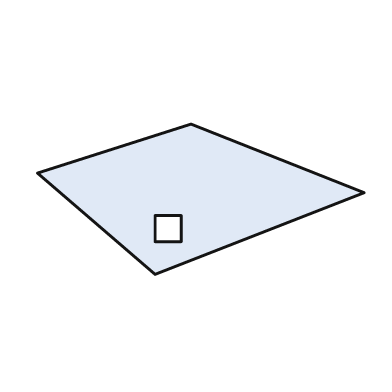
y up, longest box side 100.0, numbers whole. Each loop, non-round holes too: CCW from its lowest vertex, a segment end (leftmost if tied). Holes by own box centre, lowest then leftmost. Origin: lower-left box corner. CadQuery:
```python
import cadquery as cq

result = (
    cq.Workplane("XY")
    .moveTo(36.0, 0.0)
    .lineTo(100.0, 25.0)
    .lineTo(47.0, 46.0)
    .lineTo(0.0, 31.0)
    .close()
    .moveTo(36.0, 10.0)
    .lineTo(44.0, 10.0)
    .lineTo(44.0, 18.0)
    .lineTo(36.0, 18.0)
    .close()
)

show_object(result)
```